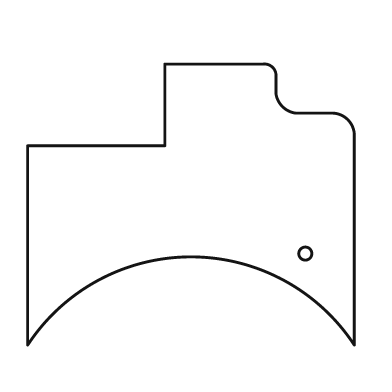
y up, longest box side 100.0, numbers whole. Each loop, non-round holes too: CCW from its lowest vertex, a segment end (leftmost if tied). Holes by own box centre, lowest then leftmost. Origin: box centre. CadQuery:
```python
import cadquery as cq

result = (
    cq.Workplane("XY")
    .moveTo(-50.0, -43.0)
    .threePointArc((0.0, -16.0), (50.0, -43.0))
    .lineTo(50.0, 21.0)
    .threePointArc((48.0, 26.0), (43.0, 28.0))
    .lineTo(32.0, 28.0)
    .threePointArc((28.0, 30.0), (26.0, 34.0))
    .lineTo(26.0, 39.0)
    .threePointArc((25.0, 42.0), (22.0, 43.0))
    .lineTo(-8.0, 43.0)
    .lineTo(-8.0, 18.0)
    .lineTo(-50.0, 18.0)
    .close()
    .moveTo(35.0, -15.0)
    .circle(2.0)
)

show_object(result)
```